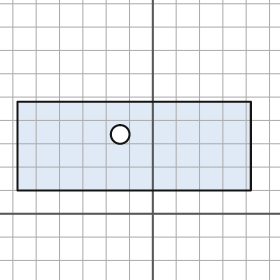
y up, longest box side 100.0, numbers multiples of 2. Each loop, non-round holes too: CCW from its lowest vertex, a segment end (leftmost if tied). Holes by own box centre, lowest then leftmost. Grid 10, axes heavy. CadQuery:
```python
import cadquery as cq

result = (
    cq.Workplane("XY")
    .moveTo(-58.0, 10.0)
    .lineTo(42.0, 10.0)
    .lineTo(42.0, 48.0)
    .lineTo(-58.0, 48.0)
    .close()
    .moveTo(-14.0, 34.0)
    .circle(4.0)
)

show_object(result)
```